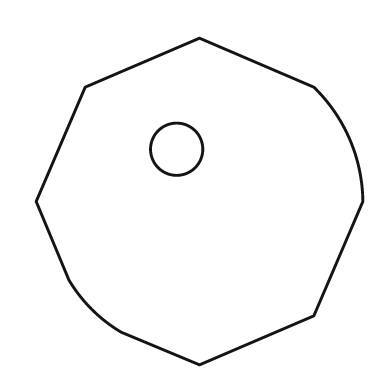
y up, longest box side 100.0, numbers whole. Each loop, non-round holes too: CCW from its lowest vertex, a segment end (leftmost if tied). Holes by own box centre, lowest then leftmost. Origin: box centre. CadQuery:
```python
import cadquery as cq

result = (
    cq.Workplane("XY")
    .moveTo(0.0, -50.0)
    .lineTo(35.0, -35.0)
    .lineTo(50.0, 0.0)
    .threePointArc((46.0, 19.0), (35.0, 35.0))
    .lineTo(0.0, 50.0)
    .lineTo(-35.0, 35.0)
    .lineTo(-50.0, 0.0)
    .lineTo(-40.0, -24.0)
    .threePointArc((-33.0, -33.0), (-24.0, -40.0))
    .close()
    .moveTo(-7.0, 16.0)
    .circle(8.0)
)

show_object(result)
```